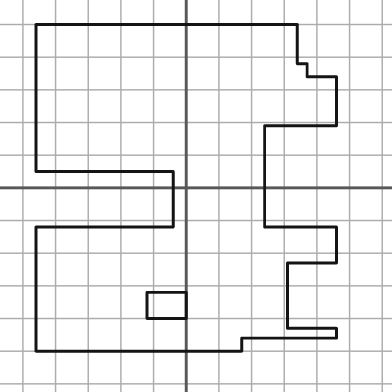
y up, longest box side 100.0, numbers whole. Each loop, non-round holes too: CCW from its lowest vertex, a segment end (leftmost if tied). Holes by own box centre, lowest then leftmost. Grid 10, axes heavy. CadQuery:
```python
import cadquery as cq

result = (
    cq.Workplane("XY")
    .moveTo(-46.0, -50.0)
    .lineTo(17.0, -50.0)
    .lineTo(17.0, -46.0)
    .lineTo(46.0, -46.0)
    .lineTo(46.0, -43.0)
    .lineTo(31.0, -43.0)
    .lineTo(31.0, -23.0)
    .lineTo(46.0, -23.0)
    .lineTo(46.0, -12.0)
    .lineTo(24.0, -12.0)
    .lineTo(24.0, 19.0)
    .lineTo(46.0, 19.0)
    .lineTo(46.0, 34.0)
    .lineTo(37.0, 34.0)
    .lineTo(37.0, 38.0)
    .lineTo(34.0, 38.0)
    .lineTo(34.0, 50.0)
    .lineTo(-46.0, 50.0)
    .lineTo(-46.0, 5.0)
    .lineTo(-4.0, 5.0)
    .lineTo(-4.0, -12.0)
    .lineTo(-46.0, -12.0)
    .close()
    .moveTo(-12.0, -40.0)
    .lineTo(0.0, -40.0)
    .lineTo(0.0, -32.0)
    .lineTo(-12.0, -32.0)
    .close()
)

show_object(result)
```